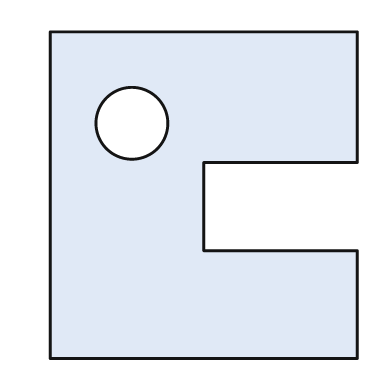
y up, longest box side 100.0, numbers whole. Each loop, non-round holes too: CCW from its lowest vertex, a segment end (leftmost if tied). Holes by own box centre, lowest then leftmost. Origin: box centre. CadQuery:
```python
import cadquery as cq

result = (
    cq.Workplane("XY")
    .moveTo(-47.0, -50.0)
    .lineTo(47.0, -50.0)
    .lineTo(47.0, -17.0)
    .lineTo(0.0, -17.0)
    .lineTo(0.0, 10.0)
    .lineTo(47.0, 10.0)
    .lineTo(47.0, 50.0)
    .lineTo(-47.0, 50.0)
    .close()
    .moveTo(-22.0, 22.0)
    .circle(11.0)
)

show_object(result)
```